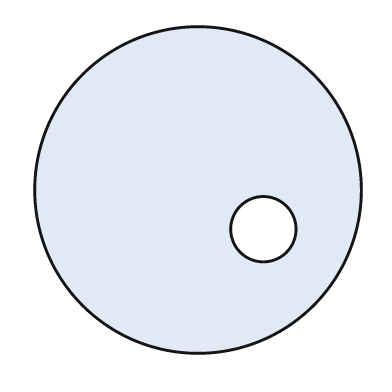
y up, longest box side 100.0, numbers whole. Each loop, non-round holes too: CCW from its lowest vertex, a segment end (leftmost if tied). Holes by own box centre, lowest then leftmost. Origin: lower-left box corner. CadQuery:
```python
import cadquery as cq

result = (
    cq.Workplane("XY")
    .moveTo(50.0, 50.0)
    .circle(50.0)
    .moveTo(70.0, 38.0)
    .circle(10.0)
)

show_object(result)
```